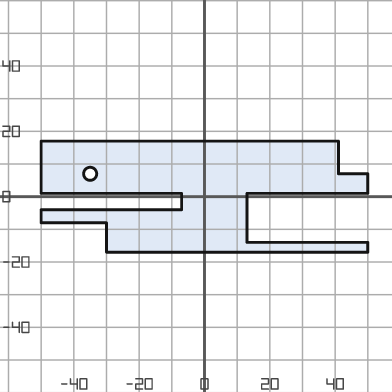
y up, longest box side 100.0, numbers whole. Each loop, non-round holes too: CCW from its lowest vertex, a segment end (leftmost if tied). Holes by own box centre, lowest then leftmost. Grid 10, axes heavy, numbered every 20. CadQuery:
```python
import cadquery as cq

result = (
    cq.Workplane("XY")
    .moveTo(-30.0, -17.0)
    .lineTo(50.0, -17.0)
    .lineTo(50.0, -14.0)
    .lineTo(13.0, -14.0)
    .lineTo(13.0, 1.0)
    .lineTo(50.0, 1.0)
    .lineTo(50.0, 7.0)
    .lineTo(41.0, 7.0)
    .lineTo(41.0, 17.0)
    .lineTo(-50.0, 17.0)
    .lineTo(-50.0, 1.0)
    .lineTo(-7.0, 1.0)
    .lineTo(-7.0, -4.0)
    .lineTo(-50.0, -4.0)
    .lineTo(-50.0, -8.0)
    .lineTo(-30.0, -8.0)
    .close()
    .moveTo(-35.0, 7.0)
    .circle(2.0)
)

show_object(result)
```